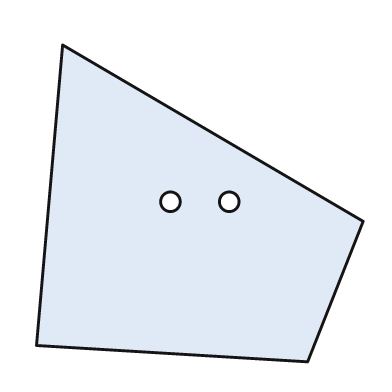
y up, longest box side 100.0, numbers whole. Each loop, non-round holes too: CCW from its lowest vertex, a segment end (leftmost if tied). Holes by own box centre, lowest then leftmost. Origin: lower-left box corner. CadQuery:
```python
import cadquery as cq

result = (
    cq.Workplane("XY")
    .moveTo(83.0, 0.0)
    .lineTo(100.0, 43.0)
    .lineTo(8.0, 97.0)
    .lineTo(0.0, 5.0)
    .close()
    .moveTo(41.0, 49.0)
    .circle(3.0)
    .moveTo(59.0, 49.0)
    .circle(3.0)
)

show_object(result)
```